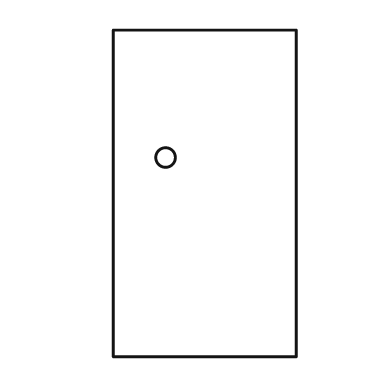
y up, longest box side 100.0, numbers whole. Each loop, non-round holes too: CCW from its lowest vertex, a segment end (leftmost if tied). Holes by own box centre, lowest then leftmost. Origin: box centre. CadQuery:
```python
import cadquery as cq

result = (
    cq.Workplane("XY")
    .moveTo(-28.0, -50.0)
    .lineTo(28.0, -50.0)
    .lineTo(28.0, 50.0)
    .lineTo(-28.0, 50.0)
    .close()
    .moveTo(-12.0, 11.0)
    .circle(3.0)
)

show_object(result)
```